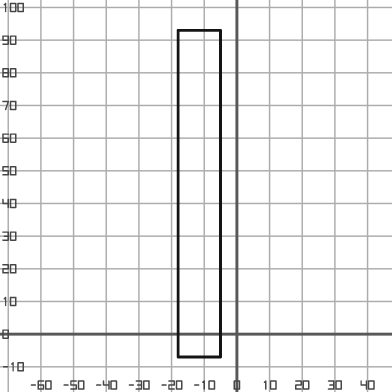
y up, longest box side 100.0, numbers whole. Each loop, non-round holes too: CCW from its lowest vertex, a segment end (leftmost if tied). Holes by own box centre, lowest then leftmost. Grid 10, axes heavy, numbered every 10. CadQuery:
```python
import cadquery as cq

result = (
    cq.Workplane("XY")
    .moveTo(-18.0, -7.0)
    .lineTo(-5.0, -7.0)
    .lineTo(-5.0, 93.0)
    .lineTo(-18.0, 93.0)
    .close()
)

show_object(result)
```